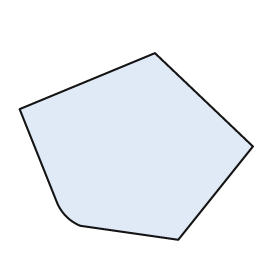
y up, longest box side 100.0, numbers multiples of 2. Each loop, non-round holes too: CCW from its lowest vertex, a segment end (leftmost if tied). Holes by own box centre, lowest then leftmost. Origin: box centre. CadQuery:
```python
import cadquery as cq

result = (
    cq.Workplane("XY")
    .moveTo(18.0, -40.0)
    .lineTo(50.0, 0.0)
    .lineTo(8.0, 40.0)
    .lineTo(-50.0, 16.0)
    .lineTo(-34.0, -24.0)
    .threePointArc((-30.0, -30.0), (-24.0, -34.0))
    .close()
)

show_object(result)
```